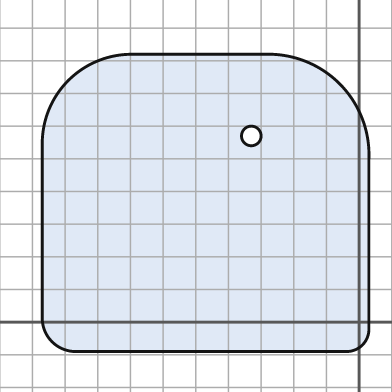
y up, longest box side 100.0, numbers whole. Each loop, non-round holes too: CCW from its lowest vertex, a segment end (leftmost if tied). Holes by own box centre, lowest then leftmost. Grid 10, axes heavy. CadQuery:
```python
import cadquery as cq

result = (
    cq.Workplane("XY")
    .moveTo(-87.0, -9.0)
    .lineTo(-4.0, -9.0)
    .threePointArc((1.0, -7.0), (3.0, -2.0))
    .lineTo(3.0, 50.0)
    .threePointArc((-6.0, 73.0), (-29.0, 82.0))
    .lineTo(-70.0, 82.0)
    .threePointArc((-89.0, 74.0), (-97.0, 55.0))
    .lineTo(-97.0, 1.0)
    .threePointArc((-94.0, -6.0), (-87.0, -9.0))
    .close()
    .moveTo(-33.0, 57.0)
    .circle(3.0)
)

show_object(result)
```